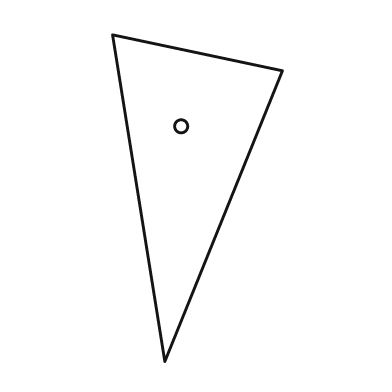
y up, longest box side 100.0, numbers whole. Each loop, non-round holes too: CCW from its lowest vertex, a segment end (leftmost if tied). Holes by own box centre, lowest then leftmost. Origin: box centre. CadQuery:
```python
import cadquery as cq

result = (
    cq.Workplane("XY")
    .moveTo(-10.0, -50.0)
    .lineTo(26.0, 39.0)
    .lineTo(-26.0, 50.0)
    .close()
    .moveTo(-5.0, 22.0)
    .circle(2.0)
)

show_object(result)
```